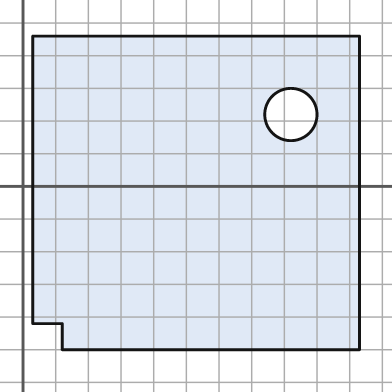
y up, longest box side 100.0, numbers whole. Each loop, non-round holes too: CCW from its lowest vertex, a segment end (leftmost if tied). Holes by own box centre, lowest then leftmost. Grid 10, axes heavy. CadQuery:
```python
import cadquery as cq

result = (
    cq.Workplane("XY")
    .moveTo(12.0, -50.0)
    .lineTo(103.0, -50.0)
    .lineTo(103.0, 46.0)
    .lineTo(3.0, 46.0)
    .lineTo(3.0, -42.0)
    .lineTo(12.0, -42.0)
    .close()
    .moveTo(82.0, 22.0)
    .circle(8.0)
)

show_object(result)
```